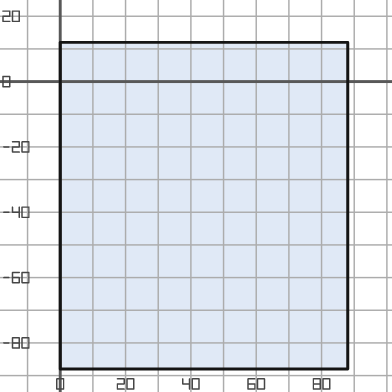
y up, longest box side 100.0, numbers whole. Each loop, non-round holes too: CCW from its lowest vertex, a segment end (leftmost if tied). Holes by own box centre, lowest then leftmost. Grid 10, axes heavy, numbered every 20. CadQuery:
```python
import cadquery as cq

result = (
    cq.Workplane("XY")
    .moveTo(0.0, -88.0)
    .lineTo(88.0, -88.0)
    .lineTo(88.0, 12.0)
    .lineTo(0.0, 12.0)
    .close()
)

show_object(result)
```